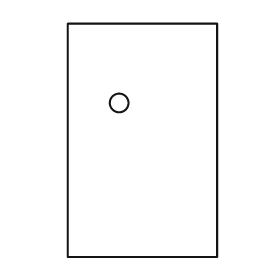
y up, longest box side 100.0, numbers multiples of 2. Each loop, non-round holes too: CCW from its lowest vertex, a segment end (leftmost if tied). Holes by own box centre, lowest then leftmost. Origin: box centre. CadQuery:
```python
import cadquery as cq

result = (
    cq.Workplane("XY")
    .moveTo(-32.0, -50.0)
    .lineTo(32.0, -50.0)
    .lineTo(32.0, 50.0)
    .lineTo(-32.0, 50.0)
    .close()
    .moveTo(-10.0, 16.0)
    .circle(4.0)
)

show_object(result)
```